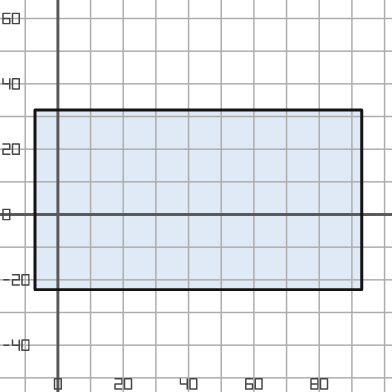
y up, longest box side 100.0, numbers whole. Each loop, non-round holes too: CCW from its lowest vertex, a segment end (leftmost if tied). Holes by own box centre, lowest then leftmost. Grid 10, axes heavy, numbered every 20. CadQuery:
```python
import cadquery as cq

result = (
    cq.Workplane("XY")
    .moveTo(-7.0, -23.0)
    .lineTo(93.0, -23.0)
    .lineTo(93.0, 32.0)
    .lineTo(-7.0, 32.0)
    .close()
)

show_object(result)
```